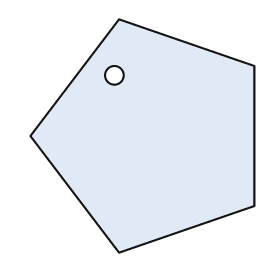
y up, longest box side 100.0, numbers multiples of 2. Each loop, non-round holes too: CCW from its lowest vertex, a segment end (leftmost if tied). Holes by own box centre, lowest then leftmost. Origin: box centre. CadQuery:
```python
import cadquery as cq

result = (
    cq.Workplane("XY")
    .moveTo(-10.0, -50.0)
    .lineTo(48.0, -30.0)
    .lineTo(48.0, 30.0)
    .lineTo(-10.0, 50.0)
    .lineTo(-48.0, 0.0)
    .close()
    .moveTo(-12.0, 26.0)
    .circle(4.0)
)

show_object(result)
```